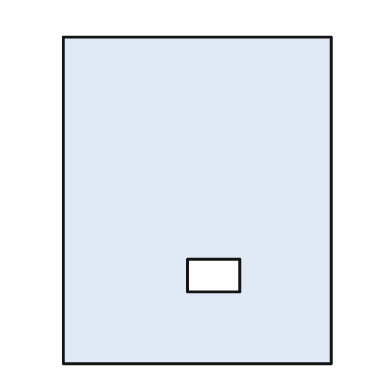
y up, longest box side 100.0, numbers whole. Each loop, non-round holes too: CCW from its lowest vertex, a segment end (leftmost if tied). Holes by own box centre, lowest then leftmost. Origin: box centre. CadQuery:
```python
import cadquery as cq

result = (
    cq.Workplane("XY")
    .moveTo(-41.0, -50.0)
    .lineTo(41.0, -50.0)
    .lineTo(41.0, 50.0)
    .lineTo(-41.0, 50.0)
    .close()
    .moveTo(-3.0, -28.0)
    .lineTo(13.0, -28.0)
    .lineTo(13.0, -18.0)
    .lineTo(-3.0, -18.0)
    .close()
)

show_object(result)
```